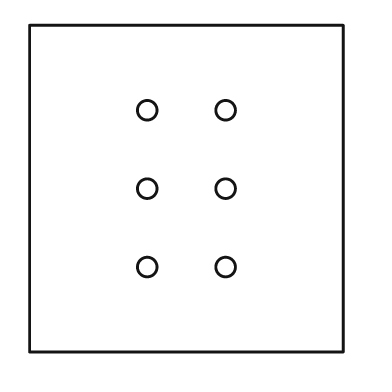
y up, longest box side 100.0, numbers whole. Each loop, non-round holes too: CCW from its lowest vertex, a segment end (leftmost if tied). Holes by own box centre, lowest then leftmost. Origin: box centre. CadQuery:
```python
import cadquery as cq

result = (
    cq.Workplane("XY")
    .moveTo(-48.0, -50.0)
    .lineTo(48.0, -50.0)
    .lineTo(48.0, 50.0)
    .lineTo(-48.0, 50.0)
    .close()
    .moveTo(-12.0, -24.0)
    .circle(3.0)
    .moveTo(12.0, -24.0)
    .circle(3.0)
    .moveTo(-12.0, 0.0)
    .circle(3.0)
    .moveTo(12.0, 0.0)
    .circle(3.0)
    .moveTo(-12.0, 24.0)
    .circle(3.0)
    .moveTo(12.0, 24.0)
    .circle(3.0)
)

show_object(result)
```